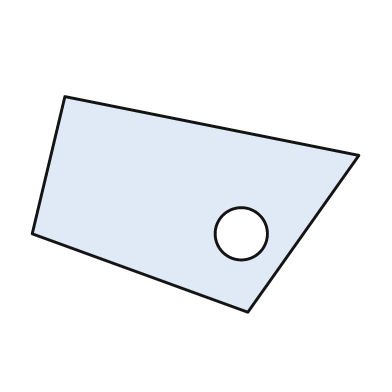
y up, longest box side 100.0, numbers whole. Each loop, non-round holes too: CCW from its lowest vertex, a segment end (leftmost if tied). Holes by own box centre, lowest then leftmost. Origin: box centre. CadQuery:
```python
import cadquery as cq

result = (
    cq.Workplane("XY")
    .moveTo(16.0, -33.0)
    .lineTo(50.0, 15.0)
    .lineTo(-40.0, 33.0)
    .lineTo(-50.0, -9.0)
    .close()
    .moveTo(14.0, -9.0)
    .circle(8.0)
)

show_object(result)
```